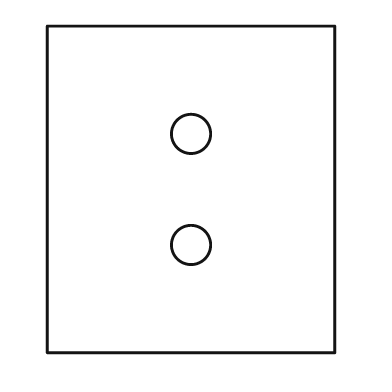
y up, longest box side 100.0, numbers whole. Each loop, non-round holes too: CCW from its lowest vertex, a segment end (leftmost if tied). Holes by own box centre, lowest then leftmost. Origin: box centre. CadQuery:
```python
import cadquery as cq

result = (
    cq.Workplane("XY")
    .moveTo(-44.0, -50.0)
    .lineTo(44.0, -50.0)
    .lineTo(44.0, 50.0)
    .lineTo(-44.0, 50.0)
    .close()
    .moveTo(0.0, -17.0)
    .circle(6.0)
    .moveTo(0.0, 17.0)
    .circle(6.0)
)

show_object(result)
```